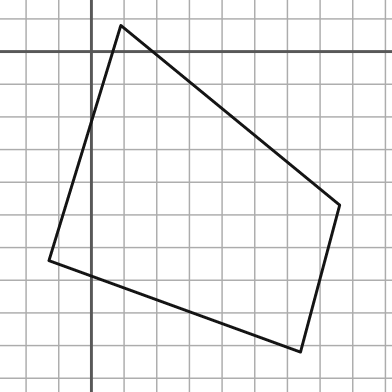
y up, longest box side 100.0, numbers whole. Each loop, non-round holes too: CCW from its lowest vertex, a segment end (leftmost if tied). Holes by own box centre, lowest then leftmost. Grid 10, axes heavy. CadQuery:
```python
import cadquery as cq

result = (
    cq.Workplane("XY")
    .moveTo(64.0, -92.0)
    .lineTo(76.0, -47.0)
    .lineTo(9.0, 8.0)
    .lineTo(-13.0, -64.0)
    .close()
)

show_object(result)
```